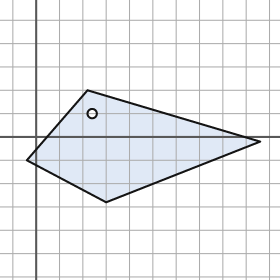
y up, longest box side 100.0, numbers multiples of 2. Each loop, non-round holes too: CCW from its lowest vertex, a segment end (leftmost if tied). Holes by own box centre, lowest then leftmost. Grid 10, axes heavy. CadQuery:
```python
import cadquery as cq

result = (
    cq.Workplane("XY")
    .moveTo(30.0, -28.0)
    .lineTo(96.0, -2.0)
    .lineTo(22.0, 20.0)
    .lineTo(-4.0, -10.0)
    .close()
    .moveTo(24.0, 10.0)
    .circle(2.0)
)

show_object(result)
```